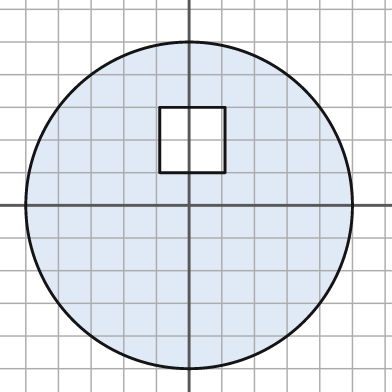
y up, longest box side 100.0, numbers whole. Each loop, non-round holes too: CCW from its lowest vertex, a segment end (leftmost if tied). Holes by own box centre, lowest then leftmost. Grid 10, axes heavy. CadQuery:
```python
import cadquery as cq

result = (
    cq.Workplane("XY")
    .moveTo(0.0, 0.0)
    .circle(50.0)
    .moveTo(-9.0, 10.0)
    .lineTo(11.0, 10.0)
    .lineTo(11.0, 30.0)
    .lineTo(-9.0, 30.0)
    .close()
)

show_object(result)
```